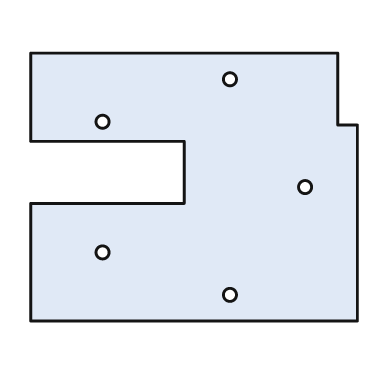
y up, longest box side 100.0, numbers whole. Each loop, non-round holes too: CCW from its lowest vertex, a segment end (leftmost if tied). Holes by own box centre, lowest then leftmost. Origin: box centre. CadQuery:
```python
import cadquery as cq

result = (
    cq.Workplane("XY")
    .moveTo(-50.0, -41.0)
    .lineTo(50.0, -41.0)
    .lineTo(50.0, 19.0)
    .lineTo(44.0, 19.0)
    .lineTo(44.0, 41.0)
    .lineTo(-50.0, 41.0)
    .lineTo(-50.0, 14.0)
    .lineTo(-3.0, 14.0)
    .lineTo(-3.0, -5.0)
    .lineTo(-50.0, -5.0)
    .close()
    .moveTo(11.0, -33.0)
    .circle(2.0)
    .moveTo(-28.0, -20.0)
    .circle(2.0)
    .moveTo(34.0, 0.0)
    .circle(2.0)
    .moveTo(-28.0, 20.0)
    .circle(2.0)
    .moveTo(11.0, 33.0)
    .circle(2.0)
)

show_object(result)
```